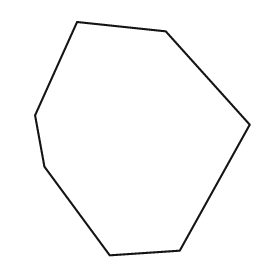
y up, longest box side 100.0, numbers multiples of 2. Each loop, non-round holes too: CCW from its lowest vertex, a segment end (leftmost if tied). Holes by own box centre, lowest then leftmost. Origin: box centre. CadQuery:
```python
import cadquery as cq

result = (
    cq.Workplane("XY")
    .moveTo(-14.0, -50.0)
    .lineTo(16.0, -48.0)
    .lineTo(46.0, 6.0)
    .lineTo(10.0, 46.0)
    .lineTo(-28.0, 50.0)
    .lineTo(-46.0, 10.0)
    .lineTo(-42.0, -12.0)
    .close()
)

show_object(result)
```